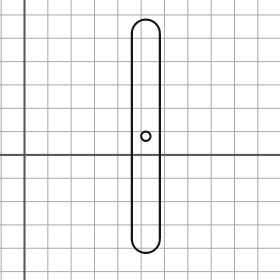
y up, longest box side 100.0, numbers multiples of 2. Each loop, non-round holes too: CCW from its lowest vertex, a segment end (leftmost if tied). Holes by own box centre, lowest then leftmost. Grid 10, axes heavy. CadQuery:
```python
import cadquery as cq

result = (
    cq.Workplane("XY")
    .moveTo(46.0, -36.0)
    .threePointArc((52.0, -42.0), (58.0, -36.0))
    .lineTo(58.0, 52.0)
    .threePointArc((52.0, 58.0), (46.0, 52.0))
    .close()
    .moveTo(52.0, 8.0)
    .circle(2.0)
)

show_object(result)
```